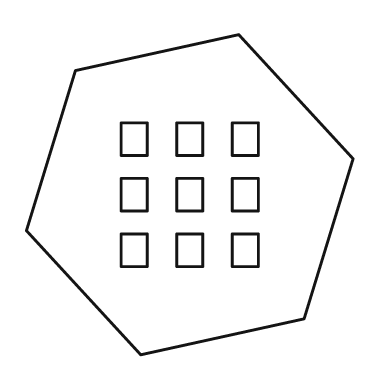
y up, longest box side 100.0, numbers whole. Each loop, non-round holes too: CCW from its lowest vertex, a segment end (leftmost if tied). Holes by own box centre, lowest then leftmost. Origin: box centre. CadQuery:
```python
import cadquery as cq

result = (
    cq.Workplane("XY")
    .moveTo(-15.0, -49.0)
    .lineTo(35.0, -38.0)
    .lineTo(50.0, 11.0)
    .lineTo(15.0, 49.0)
    .lineTo(-35.0, 38.0)
    .lineTo(-50.0, -11.0)
    .close()
    .moveTo(-21.0, -22.0)
    .lineTo(-13.0, -22.0)
    .lineTo(-13.0, -12.0)
    .lineTo(-21.0, -12.0)
    .close()
    .moveTo(-4.0, -22.0)
    .lineTo(4.0, -22.0)
    .lineTo(4.0, -12.0)
    .lineTo(-4.0, -12.0)
    .close()
    .moveTo(13.0, -22.0)
    .lineTo(21.0, -22.0)
    .lineTo(21.0, -12.0)
    .lineTo(13.0, -12.0)
    .close()
    .moveTo(-21.0, -5.0)
    .lineTo(-13.0, -5.0)
    .lineTo(-13.0, 5.0)
    .lineTo(-21.0, 5.0)
    .close()
    .moveTo(-4.0, -5.0)
    .lineTo(4.0, -5.0)
    .lineTo(4.0, 5.0)
    .lineTo(-4.0, 5.0)
    .close()
    .moveTo(13.0, -5.0)
    .lineTo(21.0, -5.0)
    .lineTo(21.0, 5.0)
    .lineTo(13.0, 5.0)
    .close()
    .moveTo(-21.0, 12.0)
    .lineTo(-13.0, 12.0)
    .lineTo(-13.0, 22.0)
    .lineTo(-21.0, 22.0)
    .close()
    .moveTo(-4.0, 12.0)
    .lineTo(4.0, 12.0)
    .lineTo(4.0, 22.0)
    .lineTo(-4.0, 22.0)
    .close()
    .moveTo(13.0, 12.0)
    .lineTo(21.0, 12.0)
    .lineTo(21.0, 22.0)
    .lineTo(13.0, 22.0)
    .close()
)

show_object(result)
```